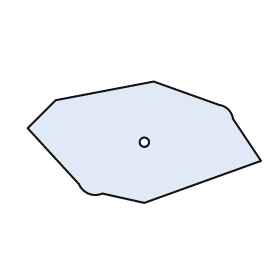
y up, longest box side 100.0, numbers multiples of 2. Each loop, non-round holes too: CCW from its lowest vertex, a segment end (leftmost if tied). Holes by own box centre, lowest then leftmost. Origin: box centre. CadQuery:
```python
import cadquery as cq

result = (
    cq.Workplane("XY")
    .moveTo(0.0, -26.0)
    .lineTo(50.0, -8.0)
    .lineTo(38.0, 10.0)
    .threePointArc((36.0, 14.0), (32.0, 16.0))
    .lineTo(4.0, 26.0)
    .lineTo(-38.0, 18.0)
    .lineTo(-50.0, 6.0)
    .lineTo(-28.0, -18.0)
    .threePointArc((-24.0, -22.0), (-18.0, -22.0))
    .close()
    .moveTo(0.0, 0.0)
    .circle(2.0)
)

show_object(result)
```